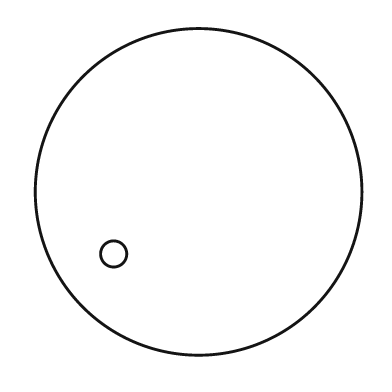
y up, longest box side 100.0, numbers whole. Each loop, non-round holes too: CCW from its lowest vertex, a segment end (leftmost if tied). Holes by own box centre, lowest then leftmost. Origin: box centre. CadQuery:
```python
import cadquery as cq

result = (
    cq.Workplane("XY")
    .moveTo(0.0, 0.0)
    .circle(50.0)
    .moveTo(-26.0, -19.0)
    .circle(4.0)
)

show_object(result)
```